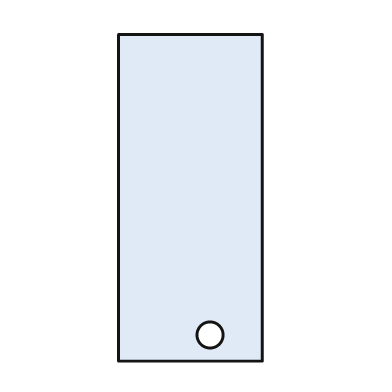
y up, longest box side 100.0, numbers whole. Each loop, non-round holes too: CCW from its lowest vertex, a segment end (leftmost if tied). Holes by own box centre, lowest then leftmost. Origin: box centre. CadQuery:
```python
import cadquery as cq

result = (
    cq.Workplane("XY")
    .moveTo(-22.0, -50.0)
    .lineTo(22.0, -50.0)
    .lineTo(22.0, 50.0)
    .lineTo(-22.0, 50.0)
    .close()
    .moveTo(6.0, -42.0)
    .circle(4.0)
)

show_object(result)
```